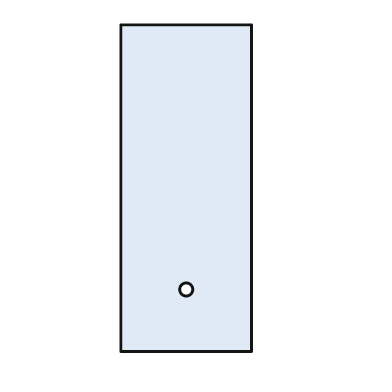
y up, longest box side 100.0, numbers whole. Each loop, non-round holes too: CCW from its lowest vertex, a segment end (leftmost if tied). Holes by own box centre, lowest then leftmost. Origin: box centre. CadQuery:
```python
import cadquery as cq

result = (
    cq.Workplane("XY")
    .moveTo(-20.0, -50.0)
    .lineTo(20.0, -50.0)
    .lineTo(20.0, 50.0)
    .lineTo(-20.0, 50.0)
    .close()
    .moveTo(0.0, -31.0)
    .circle(2.0)
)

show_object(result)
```